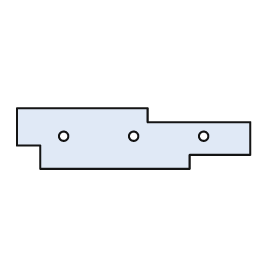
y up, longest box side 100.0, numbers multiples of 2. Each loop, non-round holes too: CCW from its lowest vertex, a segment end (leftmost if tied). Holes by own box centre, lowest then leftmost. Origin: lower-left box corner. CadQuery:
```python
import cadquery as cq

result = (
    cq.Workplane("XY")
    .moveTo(10.0, 0.0)
    .lineTo(74.0, 0.0)
    .lineTo(74.0, 6.0)
    .lineTo(100.0, 6.0)
    .lineTo(100.0, 20.0)
    .lineTo(56.0, 20.0)
    .lineTo(56.0, 26.0)
    .lineTo(0.0, 26.0)
    .lineTo(0.0, 10.0)
    .lineTo(10.0, 10.0)
    .close()
    .moveTo(20.0, 14.0)
    .circle(2.0)
    .moveTo(50.0, 14.0)
    .circle(2.0)
    .moveTo(80.0, 14.0)
    .circle(2.0)
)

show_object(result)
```